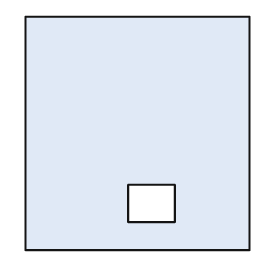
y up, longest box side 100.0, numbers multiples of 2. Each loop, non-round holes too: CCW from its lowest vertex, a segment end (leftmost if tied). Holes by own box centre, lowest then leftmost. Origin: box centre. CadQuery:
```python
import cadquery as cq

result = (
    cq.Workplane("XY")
    .moveTo(-48.0, -50.0)
    .lineTo(48.0, -50.0)
    .lineTo(48.0, 50.0)
    .lineTo(-48.0, 50.0)
    .close()
    .moveTo(-4.0, -38.0)
    .lineTo(16.0, -38.0)
    .lineTo(16.0, -22.0)
    .lineTo(-4.0, -22.0)
    .close()
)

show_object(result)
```